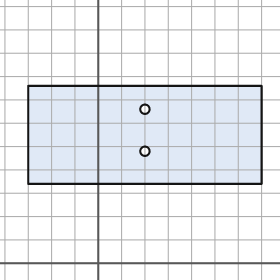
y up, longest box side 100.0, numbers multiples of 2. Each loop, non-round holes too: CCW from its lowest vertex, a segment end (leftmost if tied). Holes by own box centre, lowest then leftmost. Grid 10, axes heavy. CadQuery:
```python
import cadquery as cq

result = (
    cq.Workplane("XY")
    .moveTo(-30.0, 34.0)
    .lineTo(70.0, 34.0)
    .lineTo(70.0, 76.0)
    .lineTo(-30.0, 76.0)
    .close()
    .moveTo(20.0, 48.0)
    .circle(2.0)
    .moveTo(20.0, 66.0)
    .circle(2.0)
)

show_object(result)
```